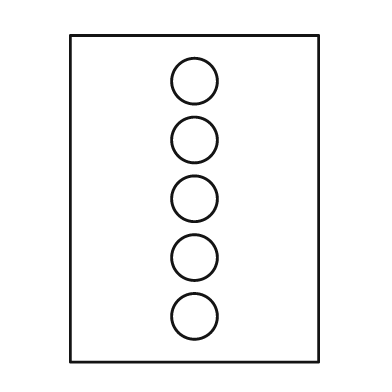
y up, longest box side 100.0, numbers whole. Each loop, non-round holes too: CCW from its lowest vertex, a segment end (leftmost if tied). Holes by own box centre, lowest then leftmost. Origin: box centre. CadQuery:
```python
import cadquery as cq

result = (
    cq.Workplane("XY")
    .moveTo(-38.0, -50.0)
    .lineTo(38.0, -50.0)
    .lineTo(38.0, 50.0)
    .lineTo(-38.0, 50.0)
    .close()
    .moveTo(0.0, -36.0)
    .circle(7.0)
    .moveTo(0.0, -18.0)
    .circle(7.0)
    .moveTo(0.0, 0.0)
    .circle(7.0)
    .moveTo(0.0, 18.0)
    .circle(7.0)
    .moveTo(0.0, 36.0)
    .circle(7.0)
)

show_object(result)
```